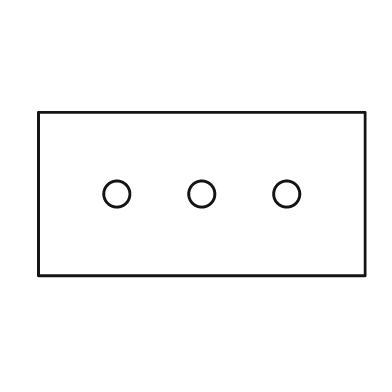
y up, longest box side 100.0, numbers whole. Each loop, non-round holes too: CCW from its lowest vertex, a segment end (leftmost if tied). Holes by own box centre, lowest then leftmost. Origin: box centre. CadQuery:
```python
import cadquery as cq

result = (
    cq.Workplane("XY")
    .moveTo(-50.0, -25.0)
    .lineTo(50.0, -25.0)
    .lineTo(50.0, 25.0)
    .lineTo(-50.0, 25.0)
    .close()
    .moveTo(-26.0, 0.0)
    .circle(4.0)
    .moveTo(0.0, 0.0)
    .circle(4.0)
    .moveTo(26.0, 0.0)
    .circle(4.0)
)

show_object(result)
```